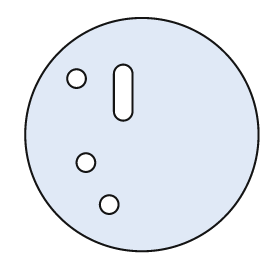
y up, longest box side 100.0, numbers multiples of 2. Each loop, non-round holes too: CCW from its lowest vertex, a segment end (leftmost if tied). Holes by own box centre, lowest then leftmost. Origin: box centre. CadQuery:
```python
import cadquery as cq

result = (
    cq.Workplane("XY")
    .moveTo(0.0, 0.0)
    .circle(50.0)
    .moveTo(-14.0, -30.0)
    .circle(4.0)
    .moveTo(-24.0, -12.0)
    .circle(4.0)
    .moveTo(-12.0, 10.0)
    .threePointArc((-8.0, 6.0), (-4.0, 10.0))
    .lineTo(-4.0, 26.0)
    .threePointArc((-8.0, 30.0), (-12.0, 26.0))
    .close()
    .moveTo(-28.0, 24.0)
    .circle(4.0)
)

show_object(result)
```